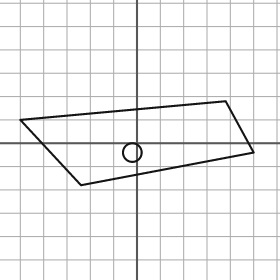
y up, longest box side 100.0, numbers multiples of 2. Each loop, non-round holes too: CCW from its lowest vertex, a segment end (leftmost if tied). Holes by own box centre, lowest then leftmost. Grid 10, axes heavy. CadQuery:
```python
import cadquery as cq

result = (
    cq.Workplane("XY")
    .moveTo(-24.0, -18.0)
    .lineTo(50.0, -4.0)
    .lineTo(38.0, 18.0)
    .lineTo(-50.0, 10.0)
    .close()
    .moveTo(-2.0, -4.0)
    .circle(4.0)
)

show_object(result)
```